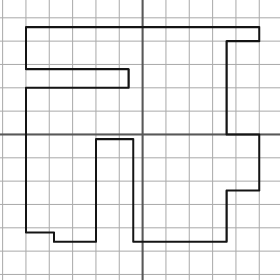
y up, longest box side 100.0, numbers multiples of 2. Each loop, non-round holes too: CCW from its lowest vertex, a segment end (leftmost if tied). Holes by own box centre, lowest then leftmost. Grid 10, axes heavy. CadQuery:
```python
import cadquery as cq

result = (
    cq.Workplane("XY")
    .moveTo(-38.0, -46.0)
    .lineTo(-20.0, -46.0)
    .lineTo(-20.0, -2.0)
    .lineTo(-4.0, -2.0)
    .lineTo(-4.0, -46.0)
    .lineTo(36.0, -46.0)
    .lineTo(36.0, -24.0)
    .lineTo(50.0, -24.0)
    .lineTo(50.0, 0.0)
    .lineTo(36.0, 0.0)
    .lineTo(36.0, 40.0)
    .lineTo(50.0, 40.0)
    .lineTo(50.0, 46.0)
    .lineTo(-50.0, 46.0)
    .lineTo(-50.0, 28.0)
    .lineTo(-6.0, 28.0)
    .lineTo(-6.0, 20.0)
    .lineTo(-50.0, 20.0)
    .lineTo(-50.0, -42.0)
    .lineTo(-38.0, -42.0)
    .close()
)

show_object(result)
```